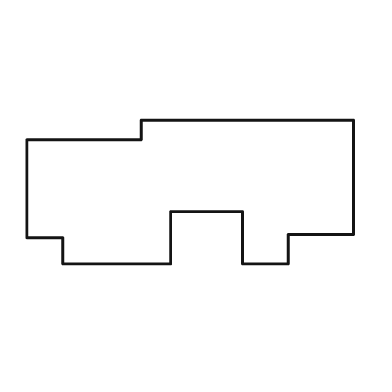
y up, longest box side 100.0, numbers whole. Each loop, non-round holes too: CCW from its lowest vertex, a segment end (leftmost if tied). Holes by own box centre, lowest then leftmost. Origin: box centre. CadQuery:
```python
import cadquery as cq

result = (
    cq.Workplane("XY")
    .moveTo(-39.0, -22.0)
    .lineTo(-6.0, -22.0)
    .lineTo(-6.0, -6.0)
    .lineTo(16.0, -6.0)
    .lineTo(16.0, -22.0)
    .lineTo(30.0, -22.0)
    .lineTo(30.0, -13.0)
    .lineTo(50.0, -13.0)
    .lineTo(50.0, 22.0)
    .lineTo(-15.0, 22.0)
    .lineTo(-15.0, 16.0)
    .lineTo(-50.0, 16.0)
    .lineTo(-50.0, -14.0)
    .lineTo(-39.0, -14.0)
    .close()
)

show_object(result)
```